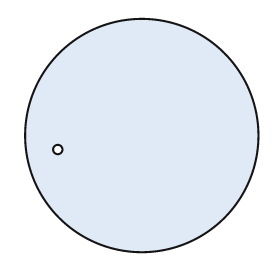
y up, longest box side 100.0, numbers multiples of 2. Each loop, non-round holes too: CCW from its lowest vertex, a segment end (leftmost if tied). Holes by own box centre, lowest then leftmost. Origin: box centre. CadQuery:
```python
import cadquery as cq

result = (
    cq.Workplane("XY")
    .moveTo(0.0, 0.0)
    .circle(50.0)
    .moveTo(-36.0, -6.0)
    .circle(2.0)
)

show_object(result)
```